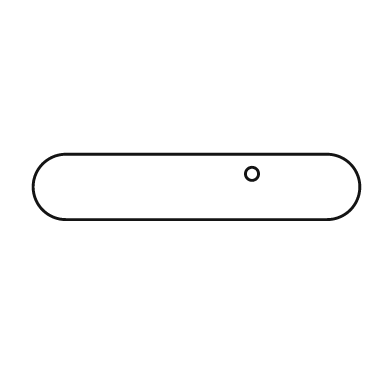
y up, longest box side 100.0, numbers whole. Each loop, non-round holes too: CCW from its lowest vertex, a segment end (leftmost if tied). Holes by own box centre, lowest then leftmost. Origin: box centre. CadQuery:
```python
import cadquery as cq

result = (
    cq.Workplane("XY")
    .moveTo(-40.0, -10.0)
    .lineTo(40.0, -10.0)
    .threePointArc((50.0, 0.0), (40.0, 10.0))
    .lineTo(-40.0, 10.0)
    .threePointArc((-50.0, 0.0), (-40.0, -10.0))
    .close()
    .moveTo(17.0, 4.0)
    .circle(2.0)
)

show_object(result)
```